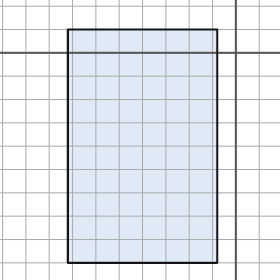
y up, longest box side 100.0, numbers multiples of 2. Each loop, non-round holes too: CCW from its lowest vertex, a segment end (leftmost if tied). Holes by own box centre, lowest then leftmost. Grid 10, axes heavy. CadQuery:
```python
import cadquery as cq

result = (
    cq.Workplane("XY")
    .moveTo(-72.0, -90.0)
    .lineTo(-8.0, -90.0)
    .lineTo(-8.0, 10.0)
    .lineTo(-72.0, 10.0)
    .close()
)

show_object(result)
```